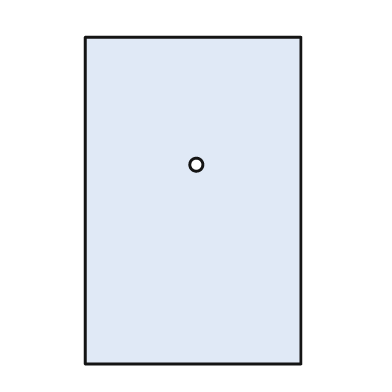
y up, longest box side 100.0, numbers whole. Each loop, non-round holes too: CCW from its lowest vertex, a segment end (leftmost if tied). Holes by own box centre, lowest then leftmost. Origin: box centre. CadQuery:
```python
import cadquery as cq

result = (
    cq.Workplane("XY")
    .moveTo(-33.0, -50.0)
    .lineTo(33.0, -50.0)
    .lineTo(33.0, 50.0)
    .lineTo(-33.0, 50.0)
    .close()
    .moveTo(1.0, 11.0)
    .circle(2.0)
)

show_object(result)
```